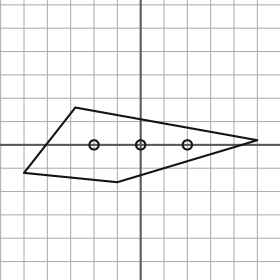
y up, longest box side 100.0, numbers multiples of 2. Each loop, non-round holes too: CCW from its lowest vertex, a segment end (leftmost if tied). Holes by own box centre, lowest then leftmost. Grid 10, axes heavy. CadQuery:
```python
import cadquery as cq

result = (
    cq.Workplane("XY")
    .moveTo(-10.0, -16.0)
    .lineTo(50.0, 2.0)
    .lineTo(-28.0, 16.0)
    .lineTo(-50.0, -12.0)
    .close()
    .moveTo(-20.0, 0.0)
    .circle(2.0)
    .moveTo(0.0, 0.0)
    .circle(2.0)
    .moveTo(20.0, 0.0)
    .circle(2.0)
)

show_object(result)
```